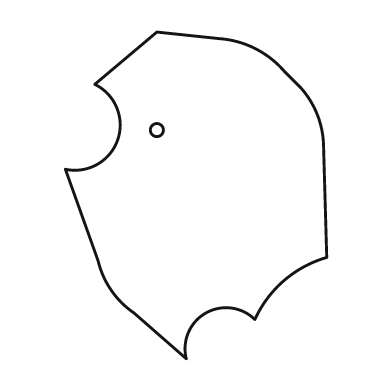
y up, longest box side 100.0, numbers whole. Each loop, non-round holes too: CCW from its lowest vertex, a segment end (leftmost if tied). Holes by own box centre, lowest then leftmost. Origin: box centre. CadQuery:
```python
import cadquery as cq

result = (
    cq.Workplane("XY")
    .moveTo(-3.0, -50.0)
    .threePointArc((3.0, -36.0), (18.0, -38.0))
    .threePointArc((27.0, -26.0), (40.0, -19.0))
    .lineTo(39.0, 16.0)
    .threePointArc((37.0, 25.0), (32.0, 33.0))
    .lineTo(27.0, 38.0)
    .threePointArc((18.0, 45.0), (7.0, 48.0))
    .lineTo(-12.0, 50.0)
    .lineTo(-31.0, 34.0)
    .threePointArc((-24.0, 17.0), (-40.0, 8.0))
    .lineTo(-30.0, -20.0)
    .threePointArc((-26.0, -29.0), (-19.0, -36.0))
    .close()
    .moveTo(-12.0, 20.0)
    .circle(2.0)
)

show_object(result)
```